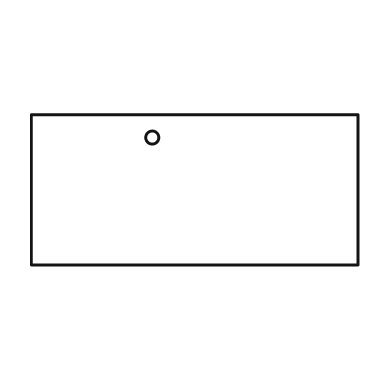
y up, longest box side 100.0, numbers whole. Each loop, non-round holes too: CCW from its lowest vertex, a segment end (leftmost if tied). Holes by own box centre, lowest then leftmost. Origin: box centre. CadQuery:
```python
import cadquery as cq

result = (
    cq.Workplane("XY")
    .moveTo(-50.0, -23.0)
    .lineTo(50.0, -23.0)
    .lineTo(50.0, 23.0)
    .lineTo(-50.0, 23.0)
    .close()
    .moveTo(-13.0, 16.0)
    .circle(2.0)
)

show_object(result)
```